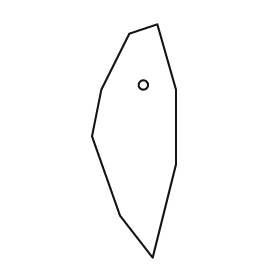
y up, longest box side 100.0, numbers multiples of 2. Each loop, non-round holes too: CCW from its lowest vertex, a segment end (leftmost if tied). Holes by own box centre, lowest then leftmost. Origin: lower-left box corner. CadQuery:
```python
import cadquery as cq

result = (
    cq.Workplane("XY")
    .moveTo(26.0, 0.0)
    .lineTo(36.0, 40.0)
    .lineTo(36.0, 72.0)
    .lineTo(28.0, 100.0)
    .lineTo(16.0, 96.0)
    .lineTo(4.0, 72.0)
    .lineTo(0.0, 52.0)
    .lineTo(12.0, 18.0)
    .close()
    .moveTo(22.0, 74.0)
    .circle(2.0)
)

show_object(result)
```